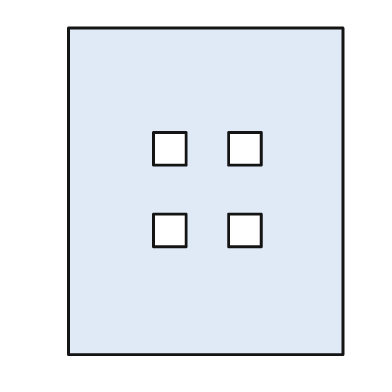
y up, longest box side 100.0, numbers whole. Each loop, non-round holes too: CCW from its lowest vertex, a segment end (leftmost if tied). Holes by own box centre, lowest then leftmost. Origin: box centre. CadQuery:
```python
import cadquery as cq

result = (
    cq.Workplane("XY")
    .moveTo(-42.0, -50.0)
    .lineTo(42.0, -50.0)
    .lineTo(42.0, 50.0)
    .lineTo(-42.0, 50.0)
    .close()
    .moveTo(-16.0, -17.0)
    .lineTo(-6.0, -17.0)
    .lineTo(-6.0, -7.0)
    .lineTo(-16.0, -7.0)
    .close()
    .moveTo(7.0, -17.0)
    .lineTo(17.0, -17.0)
    .lineTo(17.0, -7.0)
    .lineTo(7.0, -7.0)
    .close()
    .moveTo(-16.0, 8.0)
    .lineTo(-6.0, 8.0)
    .lineTo(-6.0, 18.0)
    .lineTo(-16.0, 18.0)
    .close()
    .moveTo(7.0, 8.0)
    .lineTo(17.0, 8.0)
    .lineTo(17.0, 18.0)
    .lineTo(7.0, 18.0)
    .close()
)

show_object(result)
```